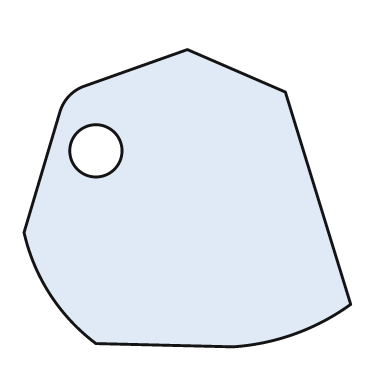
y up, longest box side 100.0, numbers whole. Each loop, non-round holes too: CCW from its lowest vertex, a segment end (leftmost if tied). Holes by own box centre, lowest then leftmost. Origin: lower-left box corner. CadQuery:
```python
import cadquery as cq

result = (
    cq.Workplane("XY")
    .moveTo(64.0, 0.0)
    .threePointArc((83.0, 4.0), (100.0, 13.0))
    .lineTo(80.0, 78.0)
    .lineTo(50.0, 91.0)
    .lineTo(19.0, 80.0)
    .threePointArc((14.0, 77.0), (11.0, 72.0))
    .lineTo(0.0, 35.0)
    .threePointArc((8.0, 16.0), (22.0, 1.0))
    .close()
    .moveTo(22.0, 60.0)
    .circle(8.0)
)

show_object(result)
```